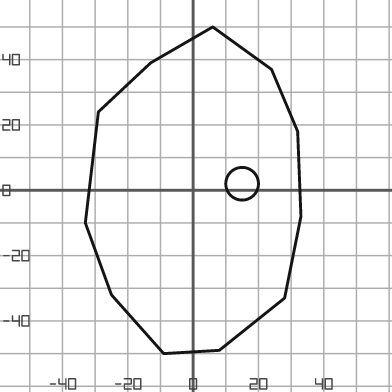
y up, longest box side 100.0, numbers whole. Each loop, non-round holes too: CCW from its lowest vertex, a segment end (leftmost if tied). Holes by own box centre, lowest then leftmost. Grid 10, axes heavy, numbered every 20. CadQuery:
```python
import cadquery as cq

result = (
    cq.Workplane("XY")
    .moveTo(-9.0, -50.0)
    .lineTo(8.0, -49.0)
    .lineTo(28.0, -33.0)
    .lineTo(33.0, -8.0)
    .lineTo(32.0, 18.0)
    .lineTo(24.0, 37.0)
    .lineTo(6.0, 50.0)
    .lineTo(-13.0, 39.0)
    .lineTo(-29.0, 24.0)
    .lineTo(-33.0, -10.0)
    .lineTo(-25.0, -32.0)
    .close()
    .moveTo(15.0, 2.0)
    .circle(5.0)
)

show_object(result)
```